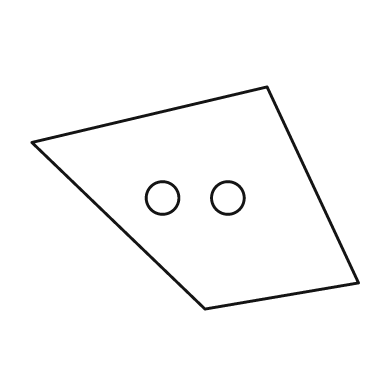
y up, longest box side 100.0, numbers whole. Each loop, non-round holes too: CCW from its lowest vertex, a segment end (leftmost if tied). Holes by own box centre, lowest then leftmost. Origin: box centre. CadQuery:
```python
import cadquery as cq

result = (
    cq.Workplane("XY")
    .moveTo(3.0, -34.0)
    .lineTo(50.0, -26.0)
    .lineTo(22.0, 34.0)
    .lineTo(-50.0, 17.0)
    .close()
    .moveTo(-10.0, 0.0)
    .circle(5.0)
    .moveTo(10.0, 0.0)
    .circle(5.0)
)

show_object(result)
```